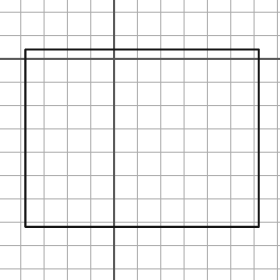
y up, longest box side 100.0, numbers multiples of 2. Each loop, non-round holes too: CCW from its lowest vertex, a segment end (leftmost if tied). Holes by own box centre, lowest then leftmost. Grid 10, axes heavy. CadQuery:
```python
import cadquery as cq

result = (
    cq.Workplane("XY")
    .moveTo(-38.0, -72.0)
    .lineTo(62.0, -72.0)
    .lineTo(62.0, 4.0)
    .lineTo(-38.0, 4.0)
    .close()
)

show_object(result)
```